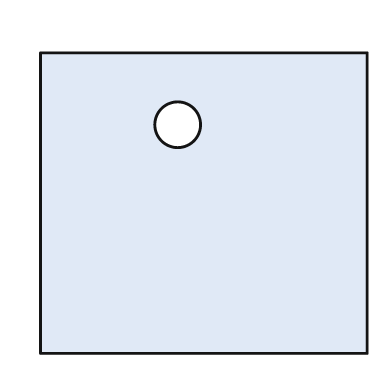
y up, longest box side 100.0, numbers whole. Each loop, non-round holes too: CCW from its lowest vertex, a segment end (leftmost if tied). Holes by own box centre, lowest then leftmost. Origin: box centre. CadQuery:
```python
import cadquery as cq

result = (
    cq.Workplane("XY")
    .moveTo(-50.0, -46.0)
    .lineTo(50.0, -46.0)
    .lineTo(50.0, 46.0)
    .lineTo(-50.0, 46.0)
    .close()
    .moveTo(-8.0, 24.0)
    .circle(7.0)
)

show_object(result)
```